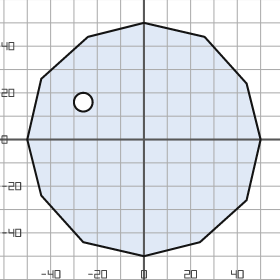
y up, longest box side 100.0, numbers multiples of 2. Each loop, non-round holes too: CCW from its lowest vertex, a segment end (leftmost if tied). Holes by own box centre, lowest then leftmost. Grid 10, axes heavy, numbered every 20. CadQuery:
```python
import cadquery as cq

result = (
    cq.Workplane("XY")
    .moveTo(0.0, -50.0)
    .lineTo(24.0, -44.0)
    .lineTo(44.0, -26.0)
    .lineTo(50.0, 0.0)
    .lineTo(44.0, 24.0)
    .lineTo(26.0, 44.0)
    .lineTo(0.0, 50.0)
    .lineTo(-24.0, 44.0)
    .lineTo(-44.0, 26.0)
    .lineTo(-50.0, 0.0)
    .lineTo(-44.0, -24.0)
    .lineTo(-26.0, -44.0)
    .close()
    .moveTo(-26.0, 16.0)
    .circle(4.0)
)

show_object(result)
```